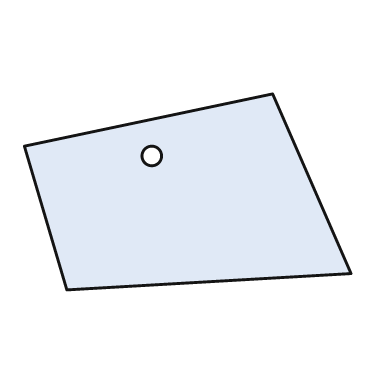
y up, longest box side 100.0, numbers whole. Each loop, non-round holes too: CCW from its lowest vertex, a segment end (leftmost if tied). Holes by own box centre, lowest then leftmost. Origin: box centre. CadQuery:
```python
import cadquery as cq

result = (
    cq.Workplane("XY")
    .moveTo(-37.0, -30.0)
    .lineTo(50.0, -25.0)
    .lineTo(26.0, 30.0)
    .lineTo(-50.0, 14.0)
    .close()
    .moveTo(-11.0, 11.0)
    .circle(3.0)
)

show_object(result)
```